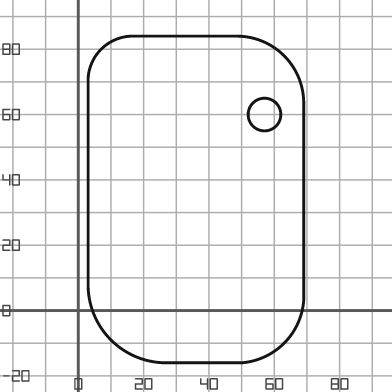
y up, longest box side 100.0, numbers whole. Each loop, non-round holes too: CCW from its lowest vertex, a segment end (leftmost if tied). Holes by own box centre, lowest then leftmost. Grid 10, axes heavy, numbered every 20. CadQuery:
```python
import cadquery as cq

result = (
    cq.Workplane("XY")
    .moveTo(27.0, -16.0)
    .lineTo(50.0, -16.0)
    .threePointArc((63.0, -10.0), (69.0, 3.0))
    .lineTo(69.0, 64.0)
    .threePointArc((63.0, 78.0), (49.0, 84.0))
    .lineTo(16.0, 84.0)
    .threePointArc((7.0, 80.0), (3.0, 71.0))
    .lineTo(3.0, 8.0)
    .threePointArc((10.0, -9.0), (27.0, -16.0))
    .close()
    .moveTo(57.0, 60.0)
    .circle(5.0)
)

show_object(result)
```